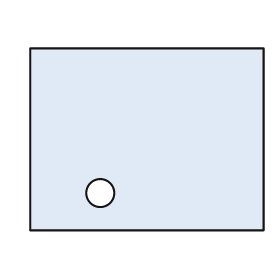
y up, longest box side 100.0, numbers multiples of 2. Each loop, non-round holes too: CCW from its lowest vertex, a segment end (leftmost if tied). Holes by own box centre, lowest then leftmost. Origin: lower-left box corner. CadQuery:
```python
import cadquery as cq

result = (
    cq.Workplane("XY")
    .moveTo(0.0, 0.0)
    .lineTo(100.0, 0.0)
    .lineTo(100.0, 78.0)
    .lineTo(0.0, 78.0)
    .close()
    .moveTo(30.0, 16.0)
    .circle(6.0)
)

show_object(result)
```